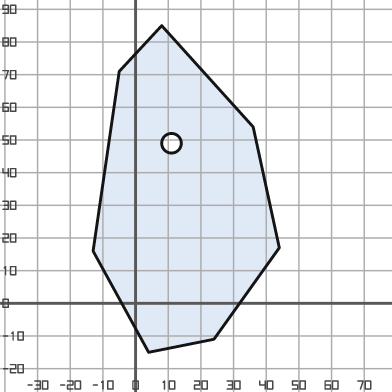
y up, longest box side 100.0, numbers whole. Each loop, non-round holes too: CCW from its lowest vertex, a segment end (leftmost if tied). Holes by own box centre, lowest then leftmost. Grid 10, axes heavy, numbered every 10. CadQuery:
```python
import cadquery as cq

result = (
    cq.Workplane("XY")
    .moveTo(4.0, -15.0)
    .lineTo(24.0, -11.0)
    .lineTo(44.0, 17.0)
    .lineTo(36.0, 54.0)
    .lineTo(8.0, 85.0)
    .lineTo(-5.0, 71.0)
    .lineTo(-13.0, 16.0)
    .close()
    .moveTo(11.0, 49.0)
    .circle(3.0)
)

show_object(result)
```